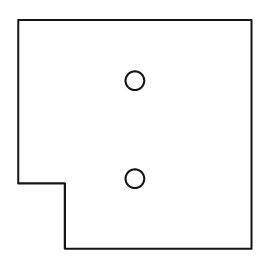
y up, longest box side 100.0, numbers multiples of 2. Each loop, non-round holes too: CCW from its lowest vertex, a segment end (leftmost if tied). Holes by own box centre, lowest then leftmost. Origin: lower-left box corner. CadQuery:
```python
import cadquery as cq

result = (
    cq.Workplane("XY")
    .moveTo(20.0, 0.0)
    .lineTo(100.0, 0.0)
    .lineTo(100.0, 98.0)
    .lineTo(0.0, 98.0)
    .lineTo(0.0, 28.0)
    .lineTo(20.0, 28.0)
    .close()
    .moveTo(50.0, 30.0)
    .circle(4.0)
    .moveTo(50.0, 72.0)
    .circle(4.0)
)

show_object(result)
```